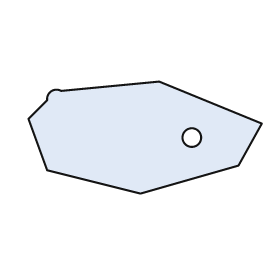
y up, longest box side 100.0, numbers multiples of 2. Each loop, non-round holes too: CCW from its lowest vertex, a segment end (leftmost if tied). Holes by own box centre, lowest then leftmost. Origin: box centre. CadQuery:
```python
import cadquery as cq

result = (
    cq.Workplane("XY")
    .moveTo(-2.0, -24.0)
    .lineTo(40.0, -12.0)
    .lineTo(50.0, 6.0)
    .lineTo(6.0, 24.0)
    .lineTo(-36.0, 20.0)
    .threePointArc((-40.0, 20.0), (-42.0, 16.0))
    .lineTo(-50.0, 8.0)
    .lineTo(-42.0, -14.0)
    .close()
    .moveTo(20.0, 0.0)
    .circle(4.0)
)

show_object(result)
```